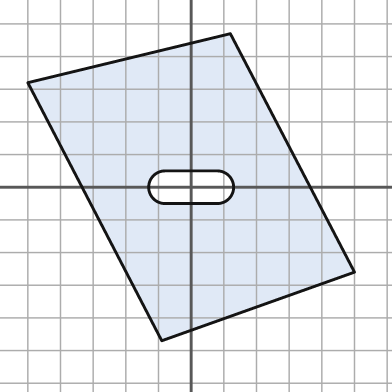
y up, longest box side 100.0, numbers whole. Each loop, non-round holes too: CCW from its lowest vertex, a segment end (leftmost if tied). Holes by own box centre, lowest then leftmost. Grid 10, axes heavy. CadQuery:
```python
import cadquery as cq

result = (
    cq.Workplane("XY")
    .moveTo(-9.0, -47.0)
    .lineTo(50.0, -26.0)
    .lineTo(12.0, 47.0)
    .lineTo(-50.0, 32.0)
    .close()
    .moveTo(-8.0, -5.0)
    .lineTo(8.0, -5.0)
    .threePointArc((13.0, 0.0), (8.0, 5.0))
    .lineTo(-8.0, 5.0)
    .threePointArc((-13.0, 0.0), (-8.0, -5.0))
    .close()
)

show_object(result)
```